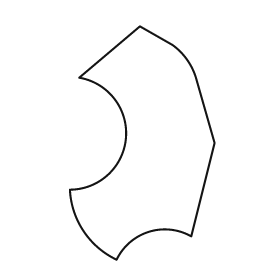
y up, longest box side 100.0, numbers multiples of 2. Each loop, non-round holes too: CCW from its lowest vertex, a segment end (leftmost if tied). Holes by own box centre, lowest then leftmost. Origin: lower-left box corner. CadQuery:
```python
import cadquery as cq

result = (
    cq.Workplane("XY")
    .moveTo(20.0, 0.0)
    .threePointArc((34.0, 12.0), (52.0, 10.0))
    .lineTo(62.0, 50.0)
    .lineTo(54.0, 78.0)
    .threePointArc((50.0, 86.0), (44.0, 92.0))
    .lineTo(30.0, 100.0)
    .lineTo(4.0, 78.0)
    .threePointArc((24.0, 52.0), (0.0, 30.0))
    .threePointArc((6.0, 12.0), (20.0, 0.0))
    .close()
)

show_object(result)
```